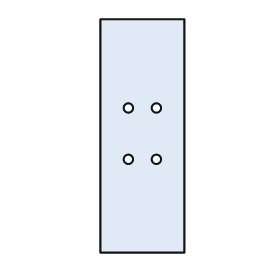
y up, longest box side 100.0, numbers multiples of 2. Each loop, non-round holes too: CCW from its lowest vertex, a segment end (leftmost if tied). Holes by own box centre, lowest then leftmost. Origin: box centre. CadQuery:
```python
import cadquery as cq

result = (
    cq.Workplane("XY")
    .moveTo(-18.0, -50.0)
    .lineTo(18.0, -50.0)
    .lineTo(18.0, 50.0)
    .lineTo(-18.0, 50.0)
    .close()
    .moveTo(-6.0, -10.0)
    .circle(2.0)
    .moveTo(6.0, -10.0)
    .circle(2.0)
    .moveTo(-6.0, 12.0)
    .circle(2.0)
    .moveTo(6.0, 12.0)
    .circle(2.0)
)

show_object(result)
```